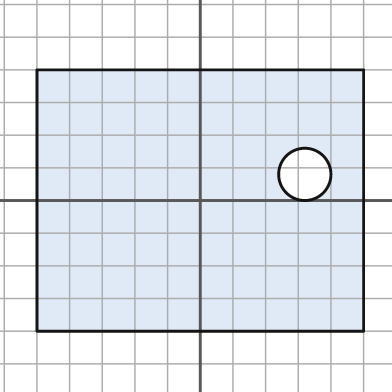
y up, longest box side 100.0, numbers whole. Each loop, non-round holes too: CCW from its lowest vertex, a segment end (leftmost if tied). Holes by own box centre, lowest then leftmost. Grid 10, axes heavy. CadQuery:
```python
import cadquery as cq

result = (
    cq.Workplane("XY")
    .moveTo(-50.0, -40.0)
    .lineTo(50.0, -40.0)
    .lineTo(50.0, 40.0)
    .lineTo(-50.0, 40.0)
    .close()
    .moveTo(32.0, 8.0)
    .circle(8.0)
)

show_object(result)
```